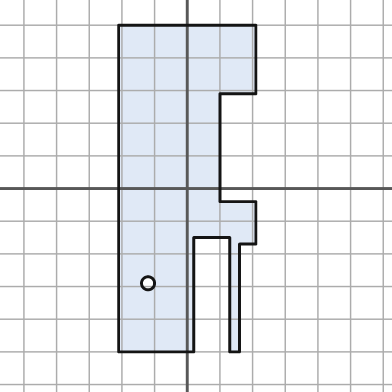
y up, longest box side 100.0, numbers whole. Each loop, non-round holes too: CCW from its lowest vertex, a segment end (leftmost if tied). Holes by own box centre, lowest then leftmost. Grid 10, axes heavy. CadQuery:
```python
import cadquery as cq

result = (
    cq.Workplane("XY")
    .moveTo(-21.0, -50.0)
    .lineTo(2.0, -50.0)
    .lineTo(2.0, -15.0)
    .lineTo(13.0, -15.0)
    .lineTo(13.0, -50.0)
    .lineTo(16.0, -50.0)
    .lineTo(16.0, -17.0)
    .lineTo(21.0, -17.0)
    .lineTo(21.0, -4.0)
    .lineTo(10.0, -4.0)
    .lineTo(10.0, 29.0)
    .lineTo(21.0, 29.0)
    .lineTo(21.0, 50.0)
    .lineTo(-21.0, 50.0)
    .close()
    .moveTo(-12.0, -29.0)
    .circle(2.0)
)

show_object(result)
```